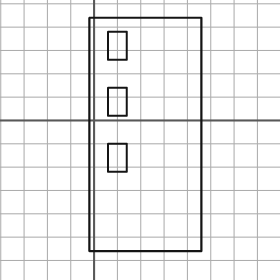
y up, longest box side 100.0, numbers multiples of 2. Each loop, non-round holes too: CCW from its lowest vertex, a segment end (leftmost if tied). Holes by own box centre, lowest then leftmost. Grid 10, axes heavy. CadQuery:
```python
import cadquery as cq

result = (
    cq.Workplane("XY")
    .moveTo(-2.0, -56.0)
    .lineTo(46.0, -56.0)
    .lineTo(46.0, 44.0)
    .lineTo(-2.0, 44.0)
    .close()
    .moveTo(6.0, -22.0)
    .lineTo(14.0, -22.0)
    .lineTo(14.0, -10.0)
    .lineTo(6.0, -10.0)
    .close()
    .moveTo(6.0, 2.0)
    .lineTo(14.0, 2.0)
    .lineTo(14.0, 14.0)
    .lineTo(6.0, 14.0)
    .close()
    .moveTo(6.0, 26.0)
    .lineTo(14.0, 26.0)
    .lineTo(14.0, 38.0)
    .lineTo(6.0, 38.0)
    .close()
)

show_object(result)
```